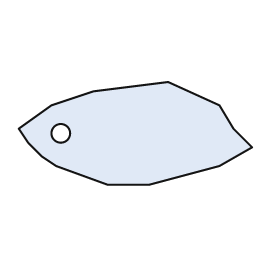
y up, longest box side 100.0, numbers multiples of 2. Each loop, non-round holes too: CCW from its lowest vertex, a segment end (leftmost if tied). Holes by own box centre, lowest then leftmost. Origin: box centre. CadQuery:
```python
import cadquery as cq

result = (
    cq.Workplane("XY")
    .moveTo(-12.0, -22.0)
    .lineTo(6.0, -22.0)
    .lineTo(36.0, -14.0)
    .lineTo(50.0, -6.0)
    .lineTo(42.0, 2.0)
    .lineTo(36.0, 12.0)
    .lineTo(14.0, 22.0)
    .lineTo(-18.0, 18.0)
    .lineTo(-36.0, 12.0)
    .lineTo(-50.0, 2.0)
    .lineTo(-46.0, -4.0)
    .lineTo(-40.0, -10.0)
    .lineTo(-34.0, -14.0)
    .close()
    .moveTo(-32.0, 0.0)
    .circle(4.0)
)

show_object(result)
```